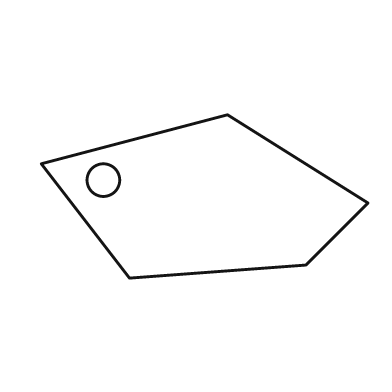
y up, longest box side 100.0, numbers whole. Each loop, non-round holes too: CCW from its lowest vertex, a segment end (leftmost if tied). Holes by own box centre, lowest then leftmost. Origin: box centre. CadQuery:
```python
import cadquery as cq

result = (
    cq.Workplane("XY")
    .moveTo(-23.0, -25.0)
    .lineTo(31.0, -21.0)
    .lineTo(50.0, -2.0)
    .lineTo(7.0, 25.0)
    .lineTo(-50.0, 10.0)
    .close()
    .moveTo(-31.0, 5.0)
    .circle(5.0)
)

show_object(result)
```